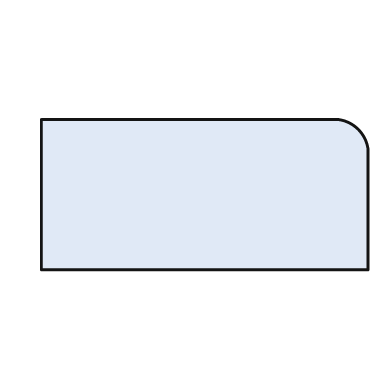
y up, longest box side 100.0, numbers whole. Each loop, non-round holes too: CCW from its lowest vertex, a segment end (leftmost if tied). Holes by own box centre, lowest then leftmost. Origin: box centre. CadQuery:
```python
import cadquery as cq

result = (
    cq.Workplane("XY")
    .moveTo(-50.0, -23.0)
    .lineTo(50.0, -23.0)
    .lineTo(50.0, 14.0)
    .threePointArc((47.0, 20.0), (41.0, 23.0))
    .lineTo(-50.0, 23.0)
    .close()
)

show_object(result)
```